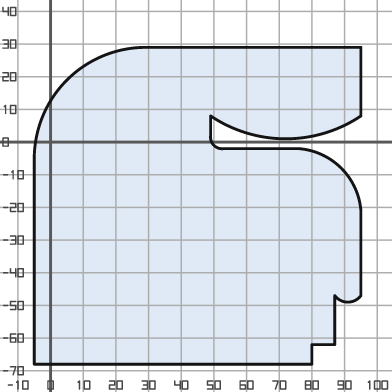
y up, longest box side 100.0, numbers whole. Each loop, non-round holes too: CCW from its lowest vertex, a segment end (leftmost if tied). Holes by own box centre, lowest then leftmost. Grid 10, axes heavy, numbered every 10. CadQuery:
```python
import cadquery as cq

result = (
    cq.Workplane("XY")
    .moveTo(-5.0, -68.0)
    .lineTo(80.0, -68.0)
    .lineTo(80.0, -62.0)
    .lineTo(87.0, -62.0)
    .lineTo(87.0, -47.0)
    .threePointArc((91.0, -49.0), (95.0, -47.0))
    .lineTo(95.0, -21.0)
    .threePointArc((89.0, -8.0), (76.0, -2.0))
    .lineTo(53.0, -2.0)
    .threePointArc((50.0, -1.0), (49.0, 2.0))
    .lineTo(49.0, 8.0)
    .threePointArc((72.0, 1.0), (95.0, 8.0))
    .lineTo(95.0, 29.0)
    .lineTo(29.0, 29.0)
    .threePointArc((5.0, 19.0), (-5.0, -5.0))
    .close()
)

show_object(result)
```